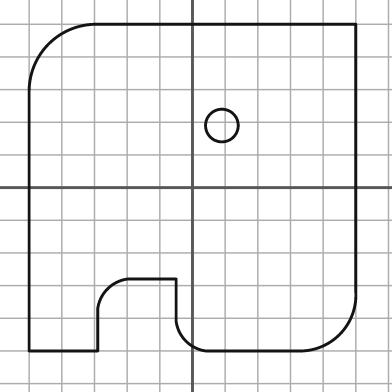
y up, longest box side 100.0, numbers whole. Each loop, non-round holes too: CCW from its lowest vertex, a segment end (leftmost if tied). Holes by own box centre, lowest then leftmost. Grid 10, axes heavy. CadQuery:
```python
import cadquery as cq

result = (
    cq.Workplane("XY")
    .moveTo(-50.0, -50.0)
    .lineTo(-29.0, -50.0)
    .lineTo(-29.0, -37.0)
    .threePointArc((-26.0, -31.0), (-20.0, -28.0))
    .lineTo(-5.0, -28.0)
    .lineTo(-5.0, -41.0)
    .threePointArc((-2.0, -47.0), (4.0, -50.0))
    .lineTo(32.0, -50.0)
    .threePointArc((45.0, -45.0), (50.0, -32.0))
    .lineTo(50.0, 50.0)
    .lineTo(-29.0, 50.0)
    .threePointArc((-44.0, 44.0), (-50.0, 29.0))
    .close()
    .moveTo(9.0, 19.0)
    .circle(5.0)
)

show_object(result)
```